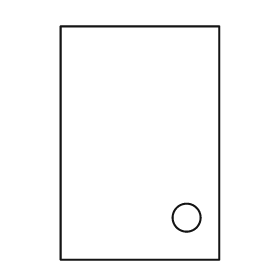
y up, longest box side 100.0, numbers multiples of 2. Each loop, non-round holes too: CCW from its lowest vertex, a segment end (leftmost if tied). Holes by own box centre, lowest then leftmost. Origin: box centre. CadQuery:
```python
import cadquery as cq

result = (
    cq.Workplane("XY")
    .moveTo(-34.0, -50.0)
    .lineTo(34.0, -50.0)
    .lineTo(34.0, 50.0)
    .lineTo(-34.0, 50.0)
    .close()
    .moveTo(20.0, -32.0)
    .circle(6.0)
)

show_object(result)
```